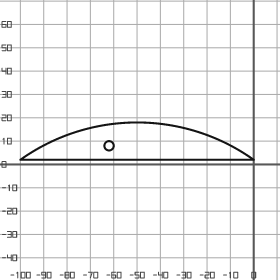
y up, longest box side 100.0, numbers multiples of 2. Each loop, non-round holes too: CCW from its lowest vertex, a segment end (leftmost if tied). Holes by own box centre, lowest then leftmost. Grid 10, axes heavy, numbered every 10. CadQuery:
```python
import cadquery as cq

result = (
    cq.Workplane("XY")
    .moveTo(-100.0, 2.0)
    .lineTo(0.0, 2.0)
    .threePointArc((-50.0, 18.0), (-100.0, 2.0))
    .close()
    .moveTo(-62.0, 8.0)
    .circle(2.0)
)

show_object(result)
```